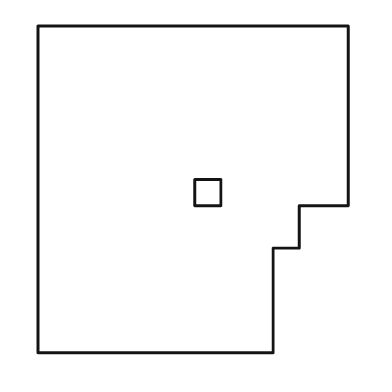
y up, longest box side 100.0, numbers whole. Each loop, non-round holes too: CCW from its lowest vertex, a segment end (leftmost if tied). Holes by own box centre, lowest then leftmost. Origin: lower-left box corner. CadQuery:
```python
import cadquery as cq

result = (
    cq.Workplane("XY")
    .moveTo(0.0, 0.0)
    .lineTo(72.0, 0.0)
    .lineTo(72.0, 32.0)
    .lineTo(80.0, 32.0)
    .lineTo(80.0, 45.0)
    .lineTo(95.0, 45.0)
    .lineTo(95.0, 100.0)
    .lineTo(0.0, 100.0)
    .close()
    .moveTo(48.0, 45.0)
    .lineTo(56.0, 45.0)
    .lineTo(56.0, 53.0)
    .lineTo(48.0, 53.0)
    .close()
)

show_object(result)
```